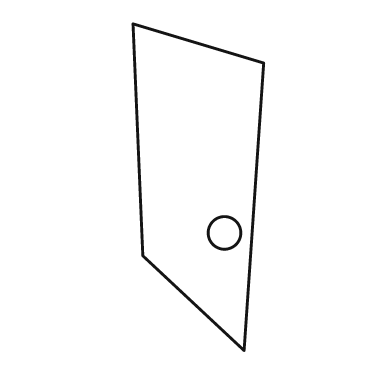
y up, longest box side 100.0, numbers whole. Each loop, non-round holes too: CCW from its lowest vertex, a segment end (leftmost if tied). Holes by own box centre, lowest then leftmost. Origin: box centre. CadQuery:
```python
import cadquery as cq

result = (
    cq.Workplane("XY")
    .moveTo(14.0, -50.0)
    .lineTo(20.0, 38.0)
    .lineTo(-20.0, 50.0)
    .lineTo(-17.0, -21.0)
    .close()
    .moveTo(8.0, -14.0)
    .circle(5.0)
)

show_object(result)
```